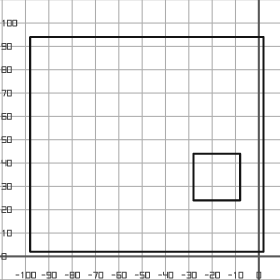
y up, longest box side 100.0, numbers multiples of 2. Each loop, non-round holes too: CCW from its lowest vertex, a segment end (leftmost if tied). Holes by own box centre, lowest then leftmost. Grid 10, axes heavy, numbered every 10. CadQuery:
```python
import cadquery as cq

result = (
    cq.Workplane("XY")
    .moveTo(-98.0, 2.0)
    .lineTo(2.0, 2.0)
    .lineTo(2.0, 94.0)
    .lineTo(-98.0, 94.0)
    .close()
    .moveTo(-28.0, 24.0)
    .lineTo(-8.0, 24.0)
    .lineTo(-8.0, 44.0)
    .lineTo(-28.0, 44.0)
    .close()
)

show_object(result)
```